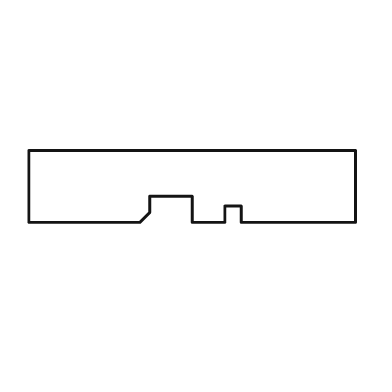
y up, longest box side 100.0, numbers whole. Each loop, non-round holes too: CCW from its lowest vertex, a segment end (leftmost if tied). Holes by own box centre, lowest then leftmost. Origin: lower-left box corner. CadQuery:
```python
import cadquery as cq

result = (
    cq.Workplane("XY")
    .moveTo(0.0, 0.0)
    .lineTo(34.0, 0.0)
    .lineTo(37.0, 3.0)
    .lineTo(37.0, 8.0)
    .lineTo(50.0, 8.0)
    .lineTo(50.0, 0.0)
    .lineTo(60.0, 0.0)
    .lineTo(60.0, 5.0)
    .lineTo(65.0, 5.0)
    .lineTo(65.0, 0.0)
    .lineTo(100.0, 0.0)
    .lineTo(100.0, 22.0)
    .lineTo(0.0, 22.0)
    .close()
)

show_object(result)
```